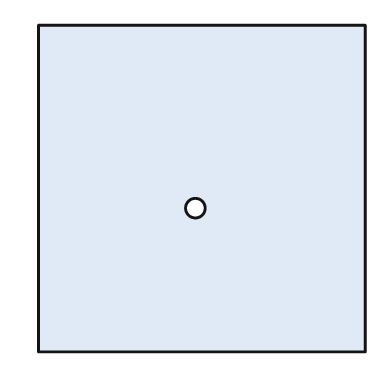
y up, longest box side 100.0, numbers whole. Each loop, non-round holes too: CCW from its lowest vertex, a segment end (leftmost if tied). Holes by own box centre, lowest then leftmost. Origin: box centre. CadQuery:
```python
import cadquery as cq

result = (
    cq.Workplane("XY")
    .moveTo(-50.0, -50.0)
    .lineTo(50.0, -50.0)
    .lineTo(50.0, 50.0)
    .lineTo(-50.0, 50.0)
    .close()
    .moveTo(-2.0, -6.0)
    .circle(3.0)
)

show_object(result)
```